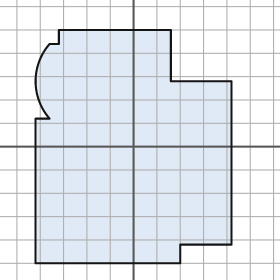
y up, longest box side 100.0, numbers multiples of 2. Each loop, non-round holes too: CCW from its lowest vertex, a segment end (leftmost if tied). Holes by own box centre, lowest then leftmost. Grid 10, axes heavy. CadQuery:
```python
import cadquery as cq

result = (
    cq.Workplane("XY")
    .moveTo(-42.0, -50.0)
    .lineTo(20.0, -50.0)
    .lineTo(20.0, -42.0)
    .lineTo(42.0, -42.0)
    .lineTo(42.0, 28.0)
    .lineTo(16.0, 28.0)
    .lineTo(16.0, 50.0)
    .lineTo(-32.0, 50.0)
    .lineTo(-32.0, 44.0)
    .lineTo(-36.0, 44.0)
    .threePointArc((-42.0, 28.0), (-36.0, 12.0))
    .lineTo(-42.0, 12.0)
    .close()
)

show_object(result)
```